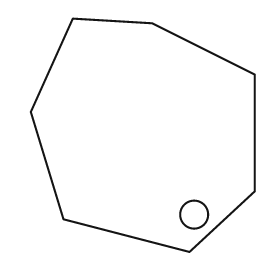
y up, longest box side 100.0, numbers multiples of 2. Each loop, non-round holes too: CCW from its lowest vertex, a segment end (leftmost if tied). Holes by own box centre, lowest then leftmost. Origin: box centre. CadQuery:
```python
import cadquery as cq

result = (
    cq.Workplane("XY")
    .moveTo(20.0, -50.0)
    .lineTo(48.0, -24.0)
    .lineTo(48.0, 26.0)
    .lineTo(4.0, 48.0)
    .lineTo(-30.0, 50.0)
    .lineTo(-48.0, 10.0)
    .lineTo(-34.0, -36.0)
    .close()
    .moveTo(22.0, -34.0)
    .circle(6.0)
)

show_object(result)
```